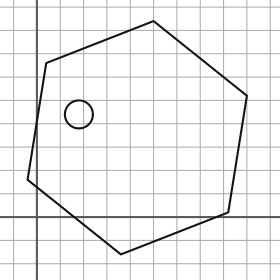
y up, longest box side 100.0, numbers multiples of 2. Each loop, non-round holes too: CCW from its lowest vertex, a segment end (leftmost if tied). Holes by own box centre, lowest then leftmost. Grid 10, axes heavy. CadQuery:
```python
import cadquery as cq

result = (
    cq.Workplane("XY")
    .moveTo(36.0, -16.0)
    .lineTo(82.0, 2.0)
    .lineTo(90.0, 52.0)
    .lineTo(50.0, 84.0)
    .lineTo(4.0, 66.0)
    .lineTo(-4.0, 16.0)
    .close()
    .moveTo(18.0, 44.0)
    .circle(6.0)
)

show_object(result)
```